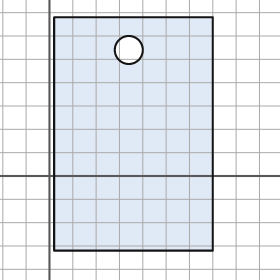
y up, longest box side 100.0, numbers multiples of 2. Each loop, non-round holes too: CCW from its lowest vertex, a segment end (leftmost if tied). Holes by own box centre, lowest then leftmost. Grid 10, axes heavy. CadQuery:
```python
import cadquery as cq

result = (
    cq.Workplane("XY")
    .moveTo(2.0, -32.0)
    .lineTo(70.0, -32.0)
    .lineTo(70.0, 68.0)
    .lineTo(2.0, 68.0)
    .close()
    .moveTo(34.0, 54.0)
    .circle(6.0)
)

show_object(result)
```